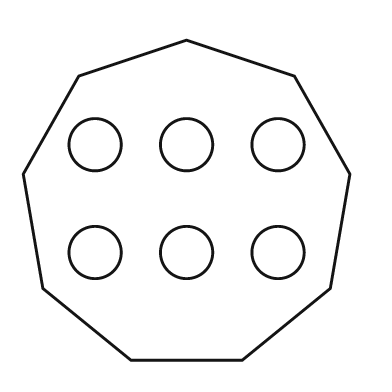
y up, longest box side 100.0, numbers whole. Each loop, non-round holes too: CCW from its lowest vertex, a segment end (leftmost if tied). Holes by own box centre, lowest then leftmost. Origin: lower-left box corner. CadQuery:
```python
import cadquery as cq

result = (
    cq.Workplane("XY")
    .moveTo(33.0, 0.0)
    .lineTo(67.0, 0.0)
    .lineTo(94.0, 22.0)
    .lineTo(100.0, 57.0)
    .lineTo(83.0, 87.0)
    .lineTo(50.0, 98.0)
    .lineTo(17.0, 87.0)
    .lineTo(0.0, 57.0)
    .lineTo(6.0, 22.0)
    .close()
    .moveTo(22.0, 33.0)
    .circle(8.0)
    .moveTo(50.0, 33.0)
    .circle(8.0)
    .moveTo(78.0, 33.0)
    .circle(8.0)
    .moveTo(22.0, 66.0)
    .circle(8.0)
    .moveTo(50.0, 66.0)
    .circle(8.0)
    .moveTo(78.0, 66.0)
    .circle(8.0)
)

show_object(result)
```